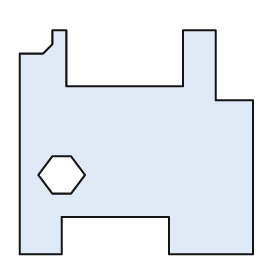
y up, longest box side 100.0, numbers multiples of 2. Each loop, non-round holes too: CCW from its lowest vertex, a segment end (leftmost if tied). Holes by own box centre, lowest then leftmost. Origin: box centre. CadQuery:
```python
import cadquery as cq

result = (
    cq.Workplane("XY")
    .moveTo(-50.0, -48.0)
    .lineTo(-32.0, -48.0)
    .lineTo(-32.0, -32.0)
    .lineTo(14.0, -32.0)
    .lineTo(14.0, -48.0)
    .lineTo(50.0, -48.0)
    .lineTo(50.0, 18.0)
    .lineTo(34.0, 18.0)
    .lineTo(34.0, 48.0)
    .lineTo(20.0, 48.0)
    .lineTo(20.0, 24.0)
    .lineTo(-30.0, 24.0)
    .lineTo(-30.0, 48.0)
    .lineTo(-36.0, 48.0)
    .lineTo(-36.0, 42.0)
    .lineTo(-40.0, 38.0)
    .lineTo(-50.0, 38.0)
    .close()
    .moveTo(-36.0, -22.0)
    .lineTo(-28.0, -22.0)
    .lineTo(-22.0, -14.0)
    .lineTo(-28.0, -6.0)
    .lineTo(-36.0, -6.0)
    .lineTo(-42.0, -14.0)
    .close()
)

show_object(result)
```